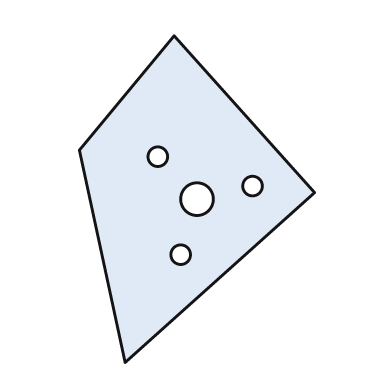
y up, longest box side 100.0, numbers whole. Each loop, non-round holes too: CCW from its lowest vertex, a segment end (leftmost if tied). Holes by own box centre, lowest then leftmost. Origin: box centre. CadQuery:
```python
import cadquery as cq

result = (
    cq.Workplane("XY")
    .moveTo(-22.0, -50.0)
    .lineTo(36.0, 2.0)
    .lineTo(-7.0, 50.0)
    .lineTo(-36.0, 15.0)
    .close()
    .moveTo(-5.0, -17.0)
    .circle(3.0)
    .moveTo(0.0, 0.0)
    .circle(5.0)
    .moveTo(17.0, 4.0)
    .circle(3.0)
    .moveTo(-12.0, 13.0)
    .circle(3.0)
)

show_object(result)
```